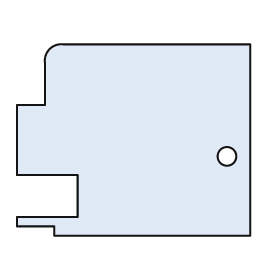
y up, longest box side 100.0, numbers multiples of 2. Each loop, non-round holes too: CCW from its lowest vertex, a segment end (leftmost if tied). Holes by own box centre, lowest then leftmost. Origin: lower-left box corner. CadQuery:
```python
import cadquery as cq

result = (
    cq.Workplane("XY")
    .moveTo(16.0, 0.0)
    .lineTo(100.0, 0.0)
    .lineTo(100.0, 82.0)
    .lineTo(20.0, 82.0)
    .threePointArc((14.0, 80.0), (12.0, 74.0))
    .lineTo(12.0, 56.0)
    .lineTo(0.0, 56.0)
    .lineTo(0.0, 26.0)
    .lineTo(26.0, 26.0)
    .lineTo(26.0, 8.0)
    .lineTo(0.0, 8.0)
    .lineTo(0.0, 4.0)
    .lineTo(16.0, 4.0)
    .close()
    .moveTo(90.0, 34.0)
    .circle(4.0)
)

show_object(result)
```